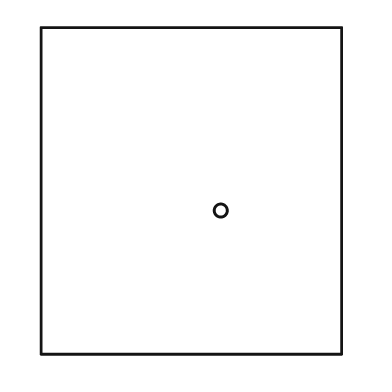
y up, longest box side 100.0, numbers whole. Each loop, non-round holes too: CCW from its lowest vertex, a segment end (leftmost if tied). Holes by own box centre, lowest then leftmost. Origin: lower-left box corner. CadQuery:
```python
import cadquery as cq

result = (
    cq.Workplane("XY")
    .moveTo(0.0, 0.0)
    .lineTo(92.0, 0.0)
    .lineTo(92.0, 100.0)
    .lineTo(0.0, 100.0)
    .close()
    .moveTo(55.0, 44.0)
    .circle(2.0)
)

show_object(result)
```